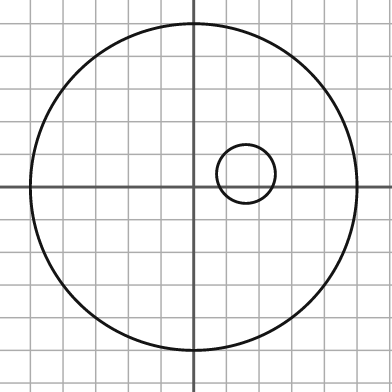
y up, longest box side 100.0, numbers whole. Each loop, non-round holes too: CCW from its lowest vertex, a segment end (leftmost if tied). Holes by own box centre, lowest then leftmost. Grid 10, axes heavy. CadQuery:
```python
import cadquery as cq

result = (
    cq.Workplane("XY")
    .moveTo(0.0, 0.0)
    .circle(50.0)
    .moveTo(16.0, 4.0)
    .circle(9.0)
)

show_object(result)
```